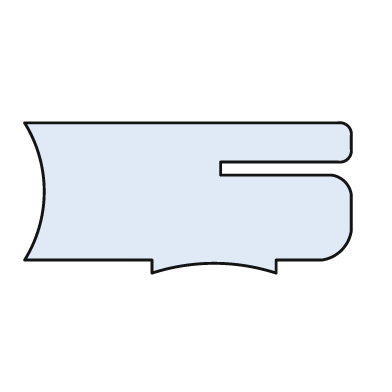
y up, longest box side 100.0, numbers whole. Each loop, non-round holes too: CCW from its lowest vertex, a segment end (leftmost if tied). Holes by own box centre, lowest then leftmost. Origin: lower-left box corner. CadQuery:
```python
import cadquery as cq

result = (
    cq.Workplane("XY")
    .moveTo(39.0, 0.0)
    .threePointArc((58.0, 3.0), (77.0, 0.0))
    .lineTo(77.0, 4.0)
    .lineTo(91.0, 4.0)
    .threePointArc((97.0, 7.0), (100.0, 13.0))
    .lineTo(100.0, 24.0)
    .threePointArc((98.0, 28.0), (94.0, 30.0))
    .lineTo(60.0, 30.0)
    .lineTo(60.0, 34.0)
    .lineTo(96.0, 34.0)
    .threePointArc((99.0, 35.0), (100.0, 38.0))
    .lineTo(100.0, 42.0)
    .threePointArc((99.0, 45.0), (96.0, 46.0))
    .lineTo(0.0, 46.0)
    .threePointArc((6.0, 25.0), (0.0, 4.0))
    .lineTo(39.0, 4.0)
    .close()
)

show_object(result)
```